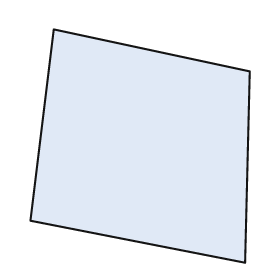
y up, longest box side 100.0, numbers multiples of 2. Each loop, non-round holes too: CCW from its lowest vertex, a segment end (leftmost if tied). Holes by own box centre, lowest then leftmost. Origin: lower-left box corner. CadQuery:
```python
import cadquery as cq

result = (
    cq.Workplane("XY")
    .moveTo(92.0, 0.0)
    .lineTo(94.0, 82.0)
    .lineTo(10.0, 100.0)
    .lineTo(0.0, 18.0)
    .close()
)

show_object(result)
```